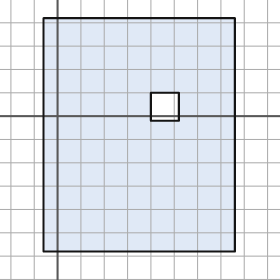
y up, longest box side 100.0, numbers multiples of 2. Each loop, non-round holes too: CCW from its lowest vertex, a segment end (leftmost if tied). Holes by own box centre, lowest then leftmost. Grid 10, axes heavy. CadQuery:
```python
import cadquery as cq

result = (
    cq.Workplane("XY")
    .moveTo(-6.0, -58.0)
    .lineTo(76.0, -58.0)
    .lineTo(76.0, 42.0)
    .lineTo(-6.0, 42.0)
    .close()
    .moveTo(40.0, -2.0)
    .lineTo(52.0, -2.0)
    .lineTo(52.0, 10.0)
    .lineTo(40.0, 10.0)
    .close()
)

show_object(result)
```